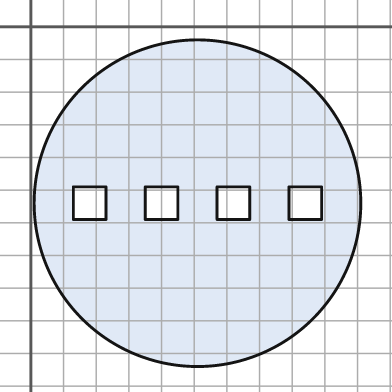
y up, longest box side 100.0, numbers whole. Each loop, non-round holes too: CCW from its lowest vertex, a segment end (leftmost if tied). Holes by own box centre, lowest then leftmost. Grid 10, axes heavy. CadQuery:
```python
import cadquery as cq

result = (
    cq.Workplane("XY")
    .moveTo(51.0, -54.0)
    .circle(50.0)
    .moveTo(13.0, -59.0)
    .lineTo(23.0, -59.0)
    .lineTo(23.0, -49.0)
    .lineTo(13.0, -49.0)
    .close()
    .moveTo(35.0, -59.0)
    .lineTo(45.0, -59.0)
    .lineTo(45.0, -49.0)
    .lineTo(35.0, -49.0)
    .close()
    .moveTo(57.0, -59.0)
    .lineTo(67.0, -59.0)
    .lineTo(67.0, -49.0)
    .lineTo(57.0, -49.0)
    .close()
    .moveTo(79.0, -59.0)
    .lineTo(89.0, -59.0)
    .lineTo(89.0, -49.0)
    .lineTo(79.0, -49.0)
    .close()
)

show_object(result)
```